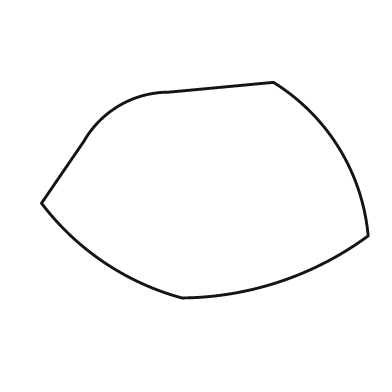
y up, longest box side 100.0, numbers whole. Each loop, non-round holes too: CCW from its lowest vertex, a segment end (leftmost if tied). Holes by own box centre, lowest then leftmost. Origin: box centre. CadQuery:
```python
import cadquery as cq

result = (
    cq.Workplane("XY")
    .moveTo(-7.0, -33.0)
    .threePointArc((23.0, -28.0), (50.0, -14.0))
    .threePointArc((41.0, 13.0), (21.0, 33.0))
    .lineTo(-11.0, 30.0)
    .threePointArc((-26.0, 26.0), (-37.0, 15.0))
    .lineTo(-50.0, -4.0)
    .threePointArc((-31.0, -22.0), (-7.0, -33.0))
    .close()
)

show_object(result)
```